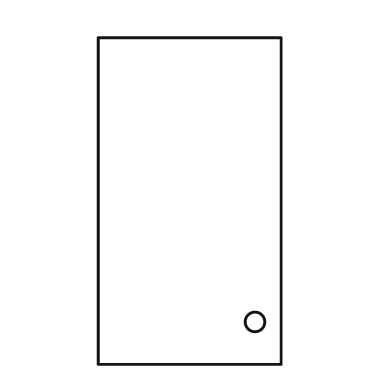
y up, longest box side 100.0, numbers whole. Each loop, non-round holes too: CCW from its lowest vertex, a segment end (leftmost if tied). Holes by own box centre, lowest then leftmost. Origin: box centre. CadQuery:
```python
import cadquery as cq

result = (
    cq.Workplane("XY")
    .moveTo(-28.0, -50.0)
    .lineTo(28.0, -50.0)
    .lineTo(28.0, 50.0)
    .lineTo(-28.0, 50.0)
    .close()
    .moveTo(20.0, -37.0)
    .circle(3.0)
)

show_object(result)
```